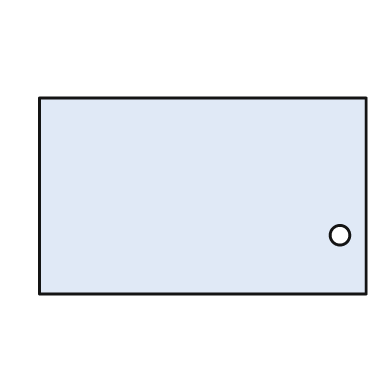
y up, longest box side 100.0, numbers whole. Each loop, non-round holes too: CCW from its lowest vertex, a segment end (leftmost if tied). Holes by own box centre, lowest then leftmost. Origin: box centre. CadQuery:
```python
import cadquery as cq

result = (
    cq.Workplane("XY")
    .moveTo(-50.0, -30.0)
    .lineTo(50.0, -30.0)
    .lineTo(50.0, 30.0)
    .lineTo(-50.0, 30.0)
    .close()
    .moveTo(42.0, -12.0)
    .circle(3.0)
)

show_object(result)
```